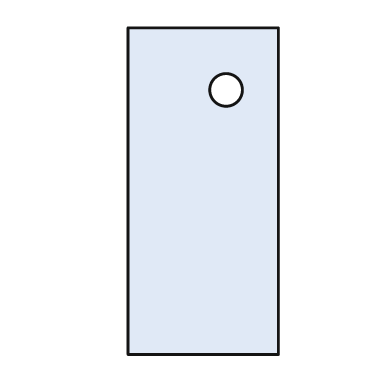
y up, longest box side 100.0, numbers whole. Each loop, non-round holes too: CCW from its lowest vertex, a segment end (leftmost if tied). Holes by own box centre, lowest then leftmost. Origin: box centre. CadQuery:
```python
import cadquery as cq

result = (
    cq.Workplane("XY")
    .moveTo(-23.0, -50.0)
    .lineTo(23.0, -50.0)
    .lineTo(23.0, 50.0)
    .lineTo(-23.0, 50.0)
    .close()
    .moveTo(7.0, 31.0)
    .circle(5.0)
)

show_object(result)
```